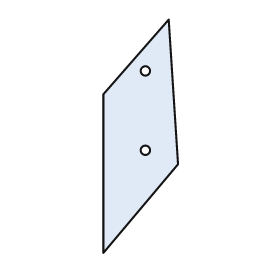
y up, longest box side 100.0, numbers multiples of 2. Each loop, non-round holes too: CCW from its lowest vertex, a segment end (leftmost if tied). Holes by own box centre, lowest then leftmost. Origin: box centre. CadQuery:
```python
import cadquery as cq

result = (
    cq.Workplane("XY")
    .moveTo(-16.0, -50.0)
    .lineTo(16.0, -12.0)
    .lineTo(12.0, 50.0)
    .lineTo(-16.0, 18.0)
    .close()
    .moveTo(2.0, -6.0)
    .circle(2.0)
    .moveTo(2.0, 28.0)
    .circle(2.0)
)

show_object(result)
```